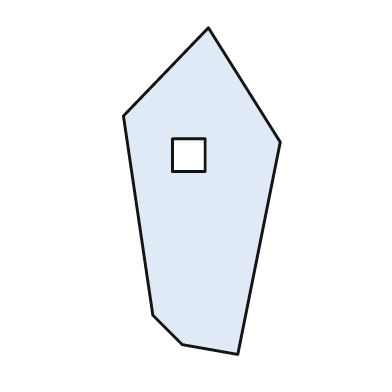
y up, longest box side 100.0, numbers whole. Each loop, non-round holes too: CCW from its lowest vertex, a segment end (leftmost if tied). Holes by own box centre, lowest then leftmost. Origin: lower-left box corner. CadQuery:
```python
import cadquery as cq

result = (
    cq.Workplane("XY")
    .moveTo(35.0, 0.0)
    .lineTo(48.0, 65.0)
    .lineTo(26.0, 100.0)
    .lineTo(0.0, 73.0)
    .lineTo(9.0, 12.0)
    .lineTo(18.0, 3.0)
    .close()
    .moveTo(15.0, 56.0)
    .lineTo(25.0, 56.0)
    .lineTo(25.0, 66.0)
    .lineTo(15.0, 66.0)
    .close()
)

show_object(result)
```